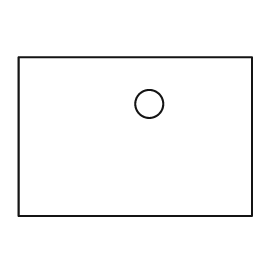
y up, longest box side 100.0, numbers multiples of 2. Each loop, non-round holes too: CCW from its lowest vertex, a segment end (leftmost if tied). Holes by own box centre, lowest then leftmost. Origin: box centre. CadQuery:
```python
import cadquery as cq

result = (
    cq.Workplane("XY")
    .moveTo(-50.0, -34.0)
    .lineTo(50.0, -34.0)
    .lineTo(50.0, 34.0)
    .lineTo(-50.0, 34.0)
    .close()
    .moveTo(6.0, 14.0)
    .circle(6.0)
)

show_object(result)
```